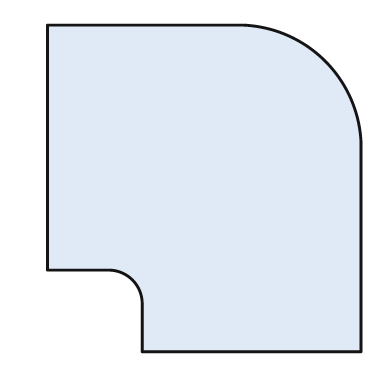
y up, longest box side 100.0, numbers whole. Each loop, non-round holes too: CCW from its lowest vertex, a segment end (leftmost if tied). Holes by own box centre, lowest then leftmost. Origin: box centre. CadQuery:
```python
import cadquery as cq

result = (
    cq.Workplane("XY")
    .moveTo(-19.0, -50.0)
    .lineTo(48.0, -50.0)
    .lineTo(48.0, 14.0)
    .threePointArc((37.0, 39.0), (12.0, 50.0))
    .lineTo(-48.0, 50.0)
    .lineTo(-48.0, -25.0)
    .lineTo(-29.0, -25.0)
    .threePointArc((-22.0, -28.0), (-19.0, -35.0))
    .close()
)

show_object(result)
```